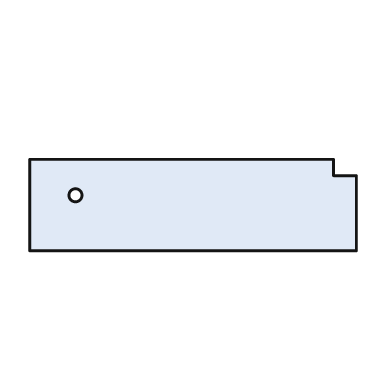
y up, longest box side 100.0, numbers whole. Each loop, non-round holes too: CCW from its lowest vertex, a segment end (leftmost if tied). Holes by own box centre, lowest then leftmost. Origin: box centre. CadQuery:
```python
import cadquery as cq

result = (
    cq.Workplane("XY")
    .moveTo(-50.0, -14.0)
    .lineTo(50.0, -14.0)
    .lineTo(50.0, 9.0)
    .lineTo(43.0, 9.0)
    .lineTo(43.0, 14.0)
    .lineTo(-50.0, 14.0)
    .close()
    .moveTo(-36.0, 3.0)
    .circle(2.0)
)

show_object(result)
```